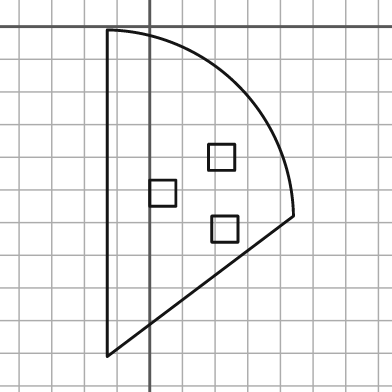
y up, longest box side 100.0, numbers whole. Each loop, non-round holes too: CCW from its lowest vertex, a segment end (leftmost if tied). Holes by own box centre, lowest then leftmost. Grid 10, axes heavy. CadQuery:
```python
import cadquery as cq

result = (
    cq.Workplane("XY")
    .moveTo(-13.0, -101.0)
    .lineTo(44.0, -58.0)
    .threePointArc((27.0, -18.0), (-13.0, -1.0))
    .close()
    .moveTo(19.0, -66.0)
    .lineTo(27.0, -66.0)
    .lineTo(27.0, -58.0)
    .lineTo(19.0, -58.0)
    .close()
    .moveTo(0.0, -55.0)
    .lineTo(8.0, -55.0)
    .lineTo(8.0, -47.0)
    .lineTo(0.0, -47.0)
    .close()
    .moveTo(18.0, -44.0)
    .lineTo(26.0, -44.0)
    .lineTo(26.0, -36.0)
    .lineTo(18.0, -36.0)
    .close()
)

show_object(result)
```